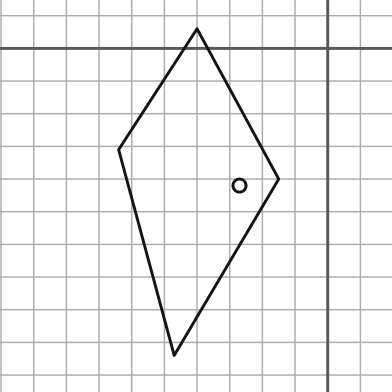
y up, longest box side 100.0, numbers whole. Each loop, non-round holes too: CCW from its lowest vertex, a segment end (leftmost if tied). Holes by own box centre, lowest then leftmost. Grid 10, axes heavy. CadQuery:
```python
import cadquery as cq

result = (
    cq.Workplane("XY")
    .moveTo(-47.0, -94.0)
    .lineTo(-15.0, -40.0)
    .lineTo(-40.0, 6.0)
    .lineTo(-64.0, -31.0)
    .close()
    .moveTo(-27.0, -42.0)
    .circle(2.0)
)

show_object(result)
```